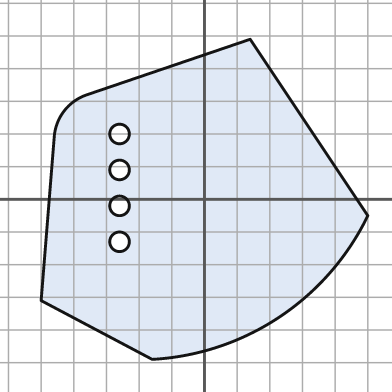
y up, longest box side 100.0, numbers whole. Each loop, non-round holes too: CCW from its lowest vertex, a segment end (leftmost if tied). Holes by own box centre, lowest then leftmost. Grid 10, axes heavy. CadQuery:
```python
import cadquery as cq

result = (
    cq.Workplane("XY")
    .moveTo(-16.0, -49.0)
    .threePointArc((23.0, -36.0), (50.0, -5.0))
    .lineTo(14.0, 49.0)
    .lineTo(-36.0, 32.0)
    .threePointArc((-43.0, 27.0), (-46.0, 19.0))
    .lineTo(-50.0, -31.0)
    .close()
    .moveTo(-26.0, -13.0)
    .circle(3.0)
    .moveTo(-26.0, -2.0)
    .circle(3.0)
    .moveTo(-26.0, 9.0)
    .circle(3.0)
    .moveTo(-26.0, 20.0)
    .circle(3.0)
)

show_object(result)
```